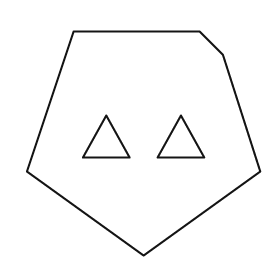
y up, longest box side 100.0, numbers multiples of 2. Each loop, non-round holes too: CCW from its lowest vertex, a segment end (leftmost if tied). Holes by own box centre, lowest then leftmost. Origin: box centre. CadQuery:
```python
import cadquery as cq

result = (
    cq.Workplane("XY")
    .moveTo(0.0, -48.0)
    .lineTo(50.0, -12.0)
    .lineTo(34.0, 38.0)
    .lineTo(24.0, 48.0)
    .lineTo(-30.0, 48.0)
    .lineTo(-50.0, -12.0)
    .close()
    .moveTo(-26.0, -6.0)
    .lineTo(-6.0, -6.0)
    .lineTo(-16.0, 12.0)
    .close()
    .moveTo(6.0, -6.0)
    .lineTo(26.0, -6.0)
    .lineTo(16.0, 12.0)
    .close()
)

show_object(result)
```